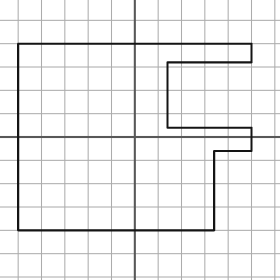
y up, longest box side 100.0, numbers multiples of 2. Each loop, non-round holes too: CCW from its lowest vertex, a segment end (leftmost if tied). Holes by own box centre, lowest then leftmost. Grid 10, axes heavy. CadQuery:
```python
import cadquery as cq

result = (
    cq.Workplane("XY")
    .moveTo(-50.0, -40.0)
    .lineTo(34.0, -40.0)
    .lineTo(34.0, -6.0)
    .lineTo(50.0, -6.0)
    .lineTo(50.0, 4.0)
    .lineTo(14.0, 4.0)
    .lineTo(14.0, 32.0)
    .lineTo(50.0, 32.0)
    .lineTo(50.0, 40.0)
    .lineTo(-50.0, 40.0)
    .close()
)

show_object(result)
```